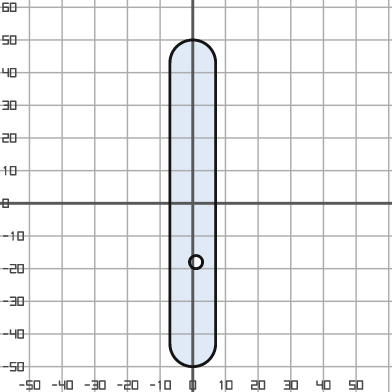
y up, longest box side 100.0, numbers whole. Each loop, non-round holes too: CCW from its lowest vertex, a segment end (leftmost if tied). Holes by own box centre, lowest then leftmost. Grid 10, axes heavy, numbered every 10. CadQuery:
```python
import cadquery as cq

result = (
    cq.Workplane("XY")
    .moveTo(-7.0, -43.0)
    .threePointArc((0.0, -50.0), (7.0, -43.0))
    .lineTo(7.0, 43.0)
    .threePointArc((0.0, 50.0), (-7.0, 43.0))
    .close()
    .moveTo(1.0, -18.0)
    .circle(2.0)
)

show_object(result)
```